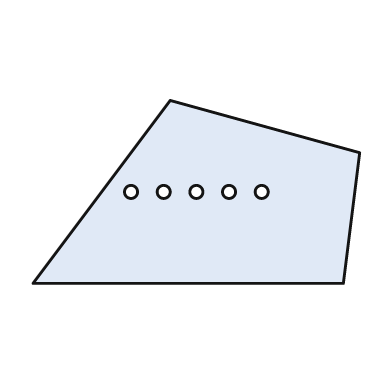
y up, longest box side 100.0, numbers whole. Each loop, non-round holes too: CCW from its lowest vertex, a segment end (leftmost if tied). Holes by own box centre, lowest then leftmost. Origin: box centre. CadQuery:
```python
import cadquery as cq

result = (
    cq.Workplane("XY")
    .moveTo(-50.0, -28.0)
    .lineTo(45.0, -28.0)
    .lineTo(50.0, 12.0)
    .lineTo(-8.0, 28.0)
    .close()
    .moveTo(-20.0, 0.0)
    .circle(2.0)
    .moveTo(-10.0, 0.0)
    .circle(2.0)
    .moveTo(0.0, 0.0)
    .circle(2.0)
    .moveTo(10.0, 0.0)
    .circle(2.0)
    .moveTo(20.0, 0.0)
    .circle(2.0)
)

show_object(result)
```